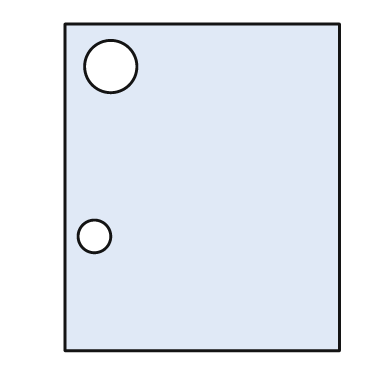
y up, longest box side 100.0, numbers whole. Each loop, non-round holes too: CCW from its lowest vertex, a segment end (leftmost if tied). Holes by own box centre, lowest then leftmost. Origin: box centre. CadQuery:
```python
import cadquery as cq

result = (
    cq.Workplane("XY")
    .moveTo(-42.0, -50.0)
    .lineTo(42.0, -50.0)
    .lineTo(42.0, 50.0)
    .lineTo(-42.0, 50.0)
    .close()
    .moveTo(-33.0, -15.0)
    .circle(5.0)
    .moveTo(-28.0, 37.0)
    .circle(8.0)
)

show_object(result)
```